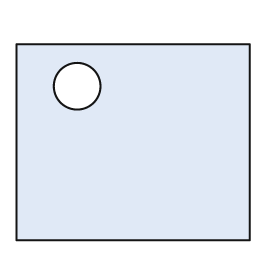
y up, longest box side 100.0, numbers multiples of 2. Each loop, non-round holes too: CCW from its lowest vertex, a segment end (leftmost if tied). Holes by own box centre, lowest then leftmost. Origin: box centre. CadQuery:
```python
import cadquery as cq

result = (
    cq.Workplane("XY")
    .moveTo(-50.0, -42.0)
    .lineTo(50.0, -42.0)
    .lineTo(50.0, 42.0)
    .lineTo(-50.0, 42.0)
    .close()
    .moveTo(-24.0, 24.0)
    .circle(10.0)
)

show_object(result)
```